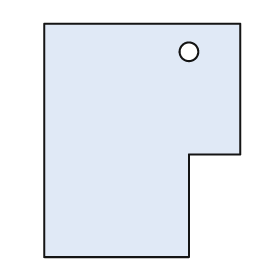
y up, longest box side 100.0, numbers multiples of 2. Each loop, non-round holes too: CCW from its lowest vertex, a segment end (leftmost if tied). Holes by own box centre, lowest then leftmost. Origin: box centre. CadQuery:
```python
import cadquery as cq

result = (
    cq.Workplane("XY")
    .moveTo(-42.0, -50.0)
    .lineTo(20.0, -50.0)
    .lineTo(20.0, -6.0)
    .lineTo(42.0, -6.0)
    .lineTo(42.0, 50.0)
    .lineTo(-42.0, 50.0)
    .close()
    .moveTo(20.0, 38.0)
    .circle(4.0)
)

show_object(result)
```